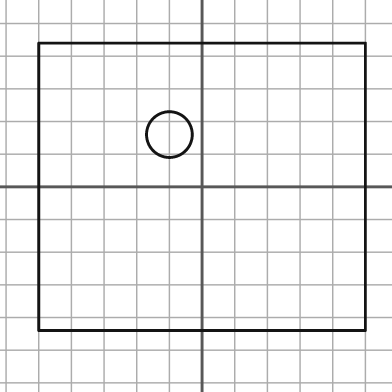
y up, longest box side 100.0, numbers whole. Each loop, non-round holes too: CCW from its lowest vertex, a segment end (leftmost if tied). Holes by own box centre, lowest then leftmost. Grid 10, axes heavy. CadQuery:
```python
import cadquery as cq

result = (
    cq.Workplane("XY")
    .moveTo(-50.0, -44.0)
    .lineTo(50.0, -44.0)
    .lineTo(50.0, 44.0)
    .lineTo(-50.0, 44.0)
    .close()
    .moveTo(-10.0, 16.0)
    .circle(7.0)
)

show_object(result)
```